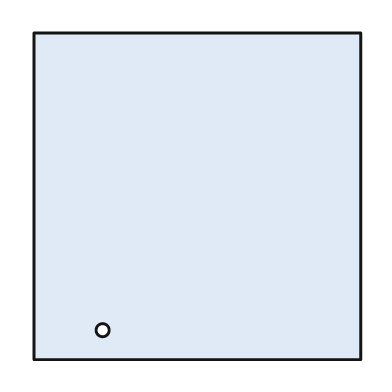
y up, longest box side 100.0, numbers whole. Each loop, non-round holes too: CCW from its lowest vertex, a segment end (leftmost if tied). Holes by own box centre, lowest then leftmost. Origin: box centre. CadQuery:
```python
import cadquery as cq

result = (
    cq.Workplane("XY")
    .moveTo(-50.0, -50.0)
    .lineTo(50.0, -50.0)
    .lineTo(50.0, 50.0)
    .lineTo(-50.0, 50.0)
    .close()
    .moveTo(-29.0, -41.0)
    .circle(2.0)
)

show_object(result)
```